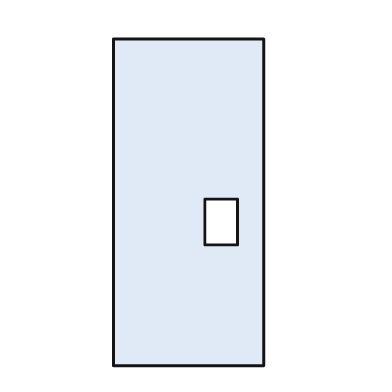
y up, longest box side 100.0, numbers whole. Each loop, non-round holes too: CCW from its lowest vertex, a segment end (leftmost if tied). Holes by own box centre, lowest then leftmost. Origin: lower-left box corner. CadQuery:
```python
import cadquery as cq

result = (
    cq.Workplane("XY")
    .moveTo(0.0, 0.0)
    .lineTo(46.0, 0.0)
    .lineTo(46.0, 100.0)
    .lineTo(0.0, 100.0)
    .close()
    .moveTo(28.0, 37.0)
    .lineTo(38.0, 37.0)
    .lineTo(38.0, 51.0)
    .lineTo(28.0, 51.0)
    .close()
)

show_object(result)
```